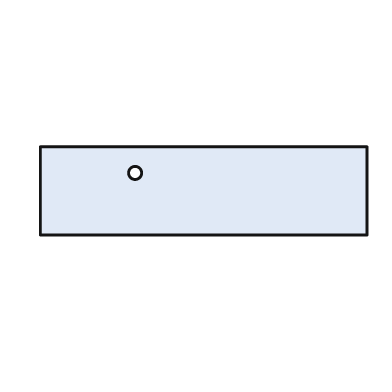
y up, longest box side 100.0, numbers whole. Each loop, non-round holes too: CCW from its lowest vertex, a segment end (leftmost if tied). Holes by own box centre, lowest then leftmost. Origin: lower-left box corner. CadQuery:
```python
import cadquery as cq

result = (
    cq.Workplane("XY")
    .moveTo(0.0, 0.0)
    .lineTo(100.0, 0.0)
    .lineTo(100.0, 27.0)
    .lineTo(0.0, 27.0)
    .close()
    .moveTo(29.0, 19.0)
    .circle(2.0)
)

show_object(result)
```